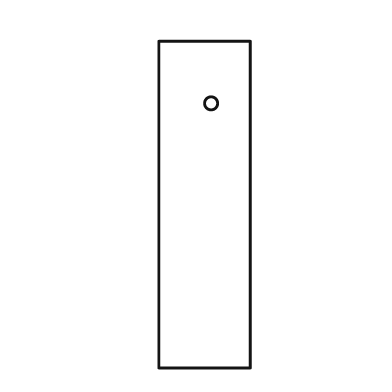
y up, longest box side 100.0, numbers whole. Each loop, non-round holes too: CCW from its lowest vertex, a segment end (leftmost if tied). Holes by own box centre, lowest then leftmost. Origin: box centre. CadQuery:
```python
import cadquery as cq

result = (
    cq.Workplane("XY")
    .moveTo(-14.0, -50.0)
    .lineTo(14.0, -50.0)
    .lineTo(14.0, 50.0)
    .lineTo(-14.0, 50.0)
    .close()
    .moveTo(2.0, 31.0)
    .circle(2.0)
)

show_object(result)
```